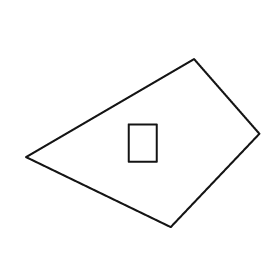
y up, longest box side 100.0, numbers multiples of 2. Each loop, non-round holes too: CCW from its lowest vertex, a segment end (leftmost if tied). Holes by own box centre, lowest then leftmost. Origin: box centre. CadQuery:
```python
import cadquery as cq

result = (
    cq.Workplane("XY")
    .moveTo(12.0, -36.0)
    .lineTo(50.0, 4.0)
    .lineTo(22.0, 36.0)
    .lineTo(-50.0, -6.0)
    .close()
    .moveTo(-6.0, -8.0)
    .lineTo(6.0, -8.0)
    .lineTo(6.0, 8.0)
    .lineTo(-6.0, 8.0)
    .close()
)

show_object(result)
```